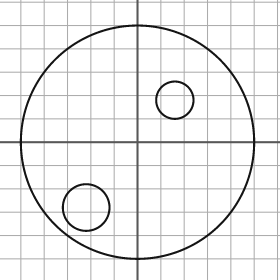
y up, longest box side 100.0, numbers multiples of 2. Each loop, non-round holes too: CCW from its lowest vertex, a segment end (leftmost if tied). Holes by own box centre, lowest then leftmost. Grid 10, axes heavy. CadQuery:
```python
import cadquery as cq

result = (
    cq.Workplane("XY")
    .moveTo(0.0, 0.0)
    .circle(50.0)
    .moveTo(-22.0, -28.0)
    .circle(10.0)
    .moveTo(16.0, 18.0)
    .circle(8.0)
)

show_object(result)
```